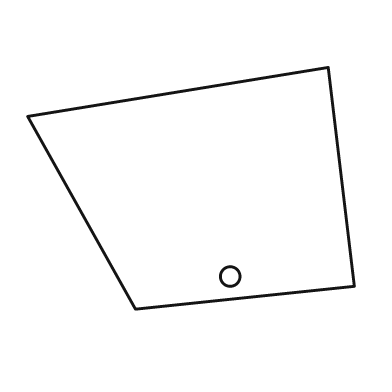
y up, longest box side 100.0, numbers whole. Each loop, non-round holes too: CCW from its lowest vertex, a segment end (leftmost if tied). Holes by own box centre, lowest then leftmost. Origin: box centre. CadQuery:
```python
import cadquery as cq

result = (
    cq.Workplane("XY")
    .moveTo(-17.0, -37.0)
    .lineTo(50.0, -30.0)
    .lineTo(42.0, 37.0)
    .lineTo(-50.0, 22.0)
    .close()
    .moveTo(12.0, -27.0)
    .circle(3.0)
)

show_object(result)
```